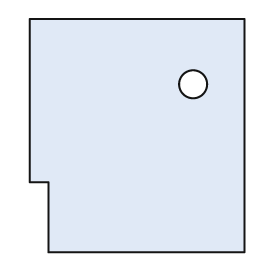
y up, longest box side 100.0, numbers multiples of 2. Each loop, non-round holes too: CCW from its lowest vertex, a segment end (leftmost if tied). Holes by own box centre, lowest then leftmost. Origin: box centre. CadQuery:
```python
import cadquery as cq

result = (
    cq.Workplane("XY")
    .moveTo(-38.0, -50.0)
    .lineTo(46.0, -50.0)
    .lineTo(46.0, 50.0)
    .lineTo(-46.0, 50.0)
    .lineTo(-46.0, -20.0)
    .lineTo(-38.0, -20.0)
    .close()
    .moveTo(24.0, 22.0)
    .circle(6.0)
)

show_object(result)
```